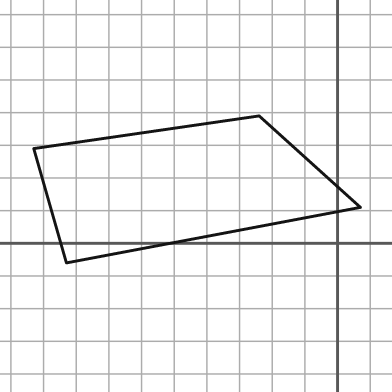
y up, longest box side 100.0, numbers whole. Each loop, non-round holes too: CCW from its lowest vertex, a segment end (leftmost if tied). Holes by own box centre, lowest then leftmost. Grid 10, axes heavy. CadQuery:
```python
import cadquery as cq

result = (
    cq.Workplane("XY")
    .moveTo(-83.0, -6.0)
    .lineTo(7.0, 11.0)
    .lineTo(-24.0, 39.0)
    .lineTo(-93.0, 29.0)
    .close()
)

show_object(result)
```